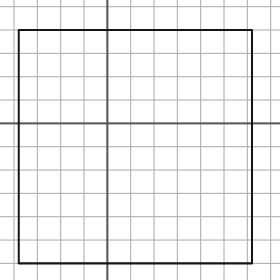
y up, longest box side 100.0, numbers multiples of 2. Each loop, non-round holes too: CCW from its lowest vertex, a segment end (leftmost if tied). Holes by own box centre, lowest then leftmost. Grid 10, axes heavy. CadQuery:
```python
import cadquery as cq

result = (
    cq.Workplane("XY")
    .moveTo(-38.0, -60.0)
    .lineTo(62.0, -60.0)
    .lineTo(62.0, 40.0)
    .lineTo(-38.0, 40.0)
    .close()
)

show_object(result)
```